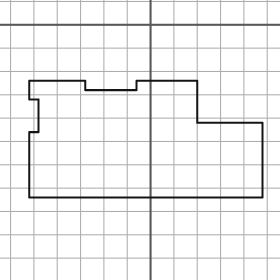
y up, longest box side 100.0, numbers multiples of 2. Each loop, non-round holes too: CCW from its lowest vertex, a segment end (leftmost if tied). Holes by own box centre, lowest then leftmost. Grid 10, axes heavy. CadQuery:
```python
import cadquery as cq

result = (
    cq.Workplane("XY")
    .moveTo(-52.0, -74.0)
    .lineTo(48.0, -74.0)
    .lineTo(48.0, -42.0)
    .lineTo(20.0, -42.0)
    .lineTo(20.0, -24.0)
    .lineTo(-6.0, -24.0)
    .lineTo(-6.0, -28.0)
    .lineTo(-28.0, -28.0)
    .lineTo(-28.0, -24.0)
    .lineTo(-52.0, -24.0)
    .lineTo(-52.0, -32.0)
    .lineTo(-48.0, -32.0)
    .lineTo(-48.0, -46.0)
    .lineTo(-52.0, -46.0)
    .close()
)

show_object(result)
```